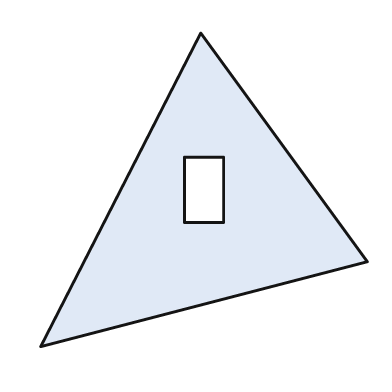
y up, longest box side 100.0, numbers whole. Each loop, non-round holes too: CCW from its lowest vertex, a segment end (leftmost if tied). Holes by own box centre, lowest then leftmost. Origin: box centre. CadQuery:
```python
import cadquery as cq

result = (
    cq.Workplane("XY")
    .moveTo(-50.0, -48.0)
    .lineTo(50.0, -22.0)
    .lineTo(-1.0, 48.0)
    .close()
    .moveTo(-6.0, -10.0)
    .lineTo(6.0, -10.0)
    .lineTo(6.0, 10.0)
    .lineTo(-6.0, 10.0)
    .close()
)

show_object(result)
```